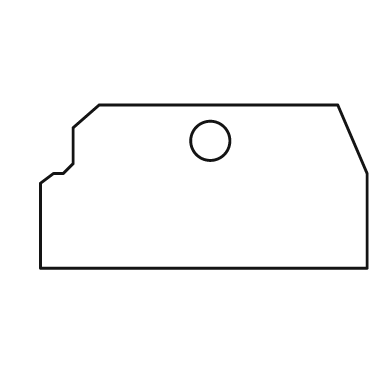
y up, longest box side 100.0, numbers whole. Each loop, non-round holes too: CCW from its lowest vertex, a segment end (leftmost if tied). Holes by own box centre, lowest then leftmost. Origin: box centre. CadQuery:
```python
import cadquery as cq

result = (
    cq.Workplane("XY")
    .moveTo(-50.0, -25.0)
    .lineTo(50.0, -25.0)
    .lineTo(50.0, 4.0)
    .lineTo(41.0, 25.0)
    .lineTo(-32.0, 25.0)
    .lineTo(-40.0, 18.0)
    .lineTo(-40.0, 7.0)
    .lineTo(-43.0, 4.0)
    .lineTo(-46.0, 4.0)
    .lineTo(-50.0, 1.0)
    .close()
    .moveTo(2.0, 14.0)
    .circle(6.0)
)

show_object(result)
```